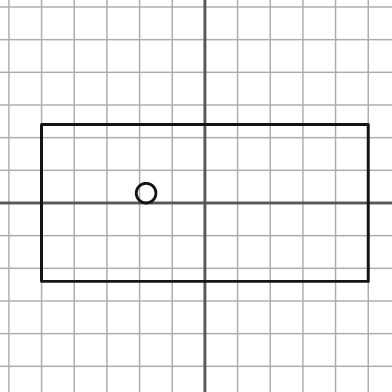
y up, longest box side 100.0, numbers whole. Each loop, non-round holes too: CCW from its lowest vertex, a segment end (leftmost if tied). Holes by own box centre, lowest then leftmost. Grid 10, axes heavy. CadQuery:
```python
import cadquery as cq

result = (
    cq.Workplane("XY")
    .moveTo(-50.0, -24.0)
    .lineTo(50.0, -24.0)
    .lineTo(50.0, 24.0)
    .lineTo(-50.0, 24.0)
    .close()
    .moveTo(-18.0, 3.0)
    .circle(3.0)
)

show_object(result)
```